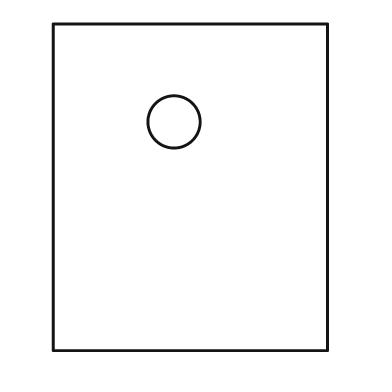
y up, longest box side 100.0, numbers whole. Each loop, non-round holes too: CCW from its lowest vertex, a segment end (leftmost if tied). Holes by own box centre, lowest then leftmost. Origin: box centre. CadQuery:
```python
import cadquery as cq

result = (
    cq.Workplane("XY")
    .moveTo(-42.0, -50.0)
    .lineTo(42.0, -50.0)
    .lineTo(42.0, 50.0)
    .lineTo(-42.0, 50.0)
    .close()
    .moveTo(-5.0, 20.0)
    .circle(8.0)
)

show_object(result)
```